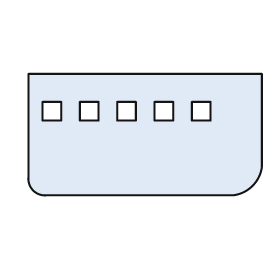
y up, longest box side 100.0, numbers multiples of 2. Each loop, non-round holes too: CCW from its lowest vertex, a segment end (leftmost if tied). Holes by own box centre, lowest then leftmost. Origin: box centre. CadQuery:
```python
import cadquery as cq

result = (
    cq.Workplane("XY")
    .moveTo(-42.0, -26.0)
    .lineTo(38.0, -26.0)
    .threePointArc((46.0, -22.0), (50.0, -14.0))
    .lineTo(50.0, 26.0)
    .lineTo(-50.0, 26.0)
    .lineTo(-50.0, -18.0)
    .threePointArc((-48.0, -24.0), (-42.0, -26.0))
    .close()
    .moveTo(-44.0, 6.0)
    .lineTo(-36.0, 6.0)
    .lineTo(-36.0, 14.0)
    .lineTo(-44.0, 14.0)
    .close()
    .moveTo(-28.0, 6.0)
    .lineTo(-20.0, 6.0)
    .lineTo(-20.0, 14.0)
    .lineTo(-28.0, 14.0)
    .close()
    .moveTo(-12.0, 6.0)
    .lineTo(-4.0, 6.0)
    .lineTo(-4.0, 14.0)
    .lineTo(-12.0, 14.0)
    .close()
    .moveTo(4.0, 6.0)
    .lineTo(12.0, 6.0)
    .lineTo(12.0, 14.0)
    .lineTo(4.0, 14.0)
    .close()
    .moveTo(20.0, 6.0)
    .lineTo(28.0, 6.0)
    .lineTo(28.0, 14.0)
    .lineTo(20.0, 14.0)
    .close()
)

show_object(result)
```